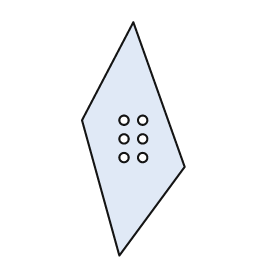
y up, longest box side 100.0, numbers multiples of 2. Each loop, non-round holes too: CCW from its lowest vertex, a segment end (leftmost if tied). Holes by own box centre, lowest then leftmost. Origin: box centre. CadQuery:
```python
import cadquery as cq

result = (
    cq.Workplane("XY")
    .moveTo(-6.0, -50.0)
    .lineTo(22.0, -12.0)
    .lineTo(0.0, 50.0)
    .lineTo(-22.0, 8.0)
    .close()
    .moveTo(-4.0, -8.0)
    .circle(2.0)
    .moveTo(4.0, -8.0)
    .circle(2.0)
    .moveTo(-4.0, 0.0)
    .circle(2.0)
    .moveTo(4.0, 0.0)
    .circle(2.0)
    .moveTo(-4.0, 8.0)
    .circle(2.0)
    .moveTo(4.0, 8.0)
    .circle(2.0)
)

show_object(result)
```